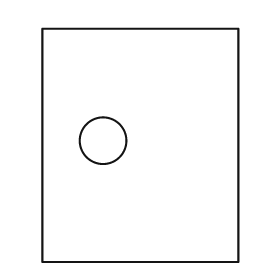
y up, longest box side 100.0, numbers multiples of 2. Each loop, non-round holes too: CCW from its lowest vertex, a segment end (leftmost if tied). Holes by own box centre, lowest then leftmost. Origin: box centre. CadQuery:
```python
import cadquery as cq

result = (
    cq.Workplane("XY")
    .moveTo(-42.0, -50.0)
    .lineTo(42.0, -50.0)
    .lineTo(42.0, 50.0)
    .lineTo(-42.0, 50.0)
    .close()
    .moveTo(-16.0, 2.0)
    .circle(10.0)
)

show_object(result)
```